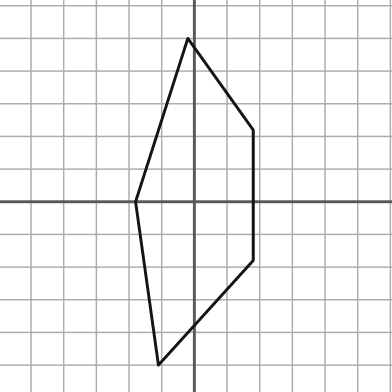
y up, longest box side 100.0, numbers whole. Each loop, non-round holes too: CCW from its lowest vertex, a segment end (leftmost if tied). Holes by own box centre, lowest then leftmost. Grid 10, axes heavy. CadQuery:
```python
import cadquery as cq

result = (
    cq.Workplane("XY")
    .moveTo(-11.0, -50.0)
    .lineTo(18.0, -18.0)
    .lineTo(18.0, 22.0)
    .lineTo(-2.0, 50.0)
    .lineTo(-18.0, 0.0)
    .close()
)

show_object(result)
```